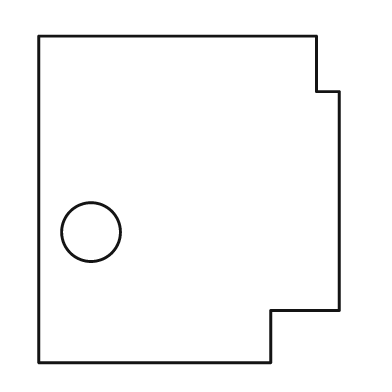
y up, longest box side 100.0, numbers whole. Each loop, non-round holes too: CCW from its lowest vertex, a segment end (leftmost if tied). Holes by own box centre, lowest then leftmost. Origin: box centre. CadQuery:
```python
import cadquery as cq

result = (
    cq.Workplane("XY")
    .moveTo(-46.0, -50.0)
    .lineTo(25.0, -50.0)
    .lineTo(25.0, -34.0)
    .lineTo(46.0, -34.0)
    .lineTo(46.0, 33.0)
    .lineTo(39.0, 33.0)
    .lineTo(39.0, 50.0)
    .lineTo(-46.0, 50.0)
    .close()
    .moveTo(-30.0, -10.0)
    .circle(9.0)
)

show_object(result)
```